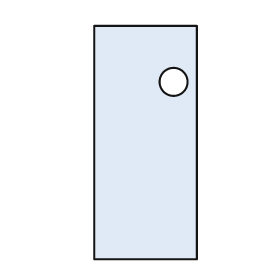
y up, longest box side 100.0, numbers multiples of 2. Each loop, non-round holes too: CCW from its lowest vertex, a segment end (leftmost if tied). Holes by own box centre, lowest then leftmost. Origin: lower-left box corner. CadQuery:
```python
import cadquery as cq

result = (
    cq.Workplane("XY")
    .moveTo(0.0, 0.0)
    .lineTo(44.0, 0.0)
    .lineTo(44.0, 100.0)
    .lineTo(0.0, 100.0)
    .close()
    .moveTo(34.0, 76.0)
    .circle(6.0)
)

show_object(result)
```